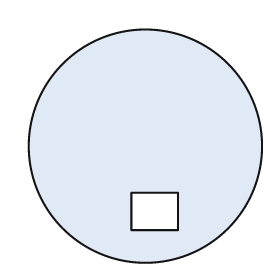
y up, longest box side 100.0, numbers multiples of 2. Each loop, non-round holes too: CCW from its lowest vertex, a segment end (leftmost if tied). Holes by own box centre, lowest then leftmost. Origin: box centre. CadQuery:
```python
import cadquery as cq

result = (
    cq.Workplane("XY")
    .moveTo(0.0, 0.0)
    .circle(50.0)
    .moveTo(-6.0, -36.0)
    .lineTo(14.0, -36.0)
    .lineTo(14.0, -20.0)
    .lineTo(-6.0, -20.0)
    .close()
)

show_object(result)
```